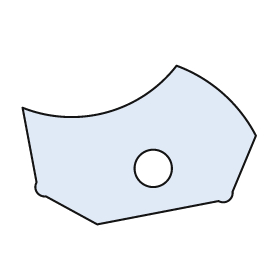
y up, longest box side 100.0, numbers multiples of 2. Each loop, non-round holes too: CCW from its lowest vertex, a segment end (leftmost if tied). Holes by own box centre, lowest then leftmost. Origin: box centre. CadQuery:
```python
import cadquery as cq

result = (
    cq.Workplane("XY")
    .moveTo(-18.0, -34.0)
    .lineTo(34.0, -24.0)
    .threePointArc((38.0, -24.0), (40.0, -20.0))
    .lineTo(50.0, 4.0)
    .threePointArc((36.0, 22.0), (16.0, 34.0))
    .threePointArc((-14.0, 14.0), (-50.0, 16.0))
    .lineTo(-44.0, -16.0)
    .threePointArc((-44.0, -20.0), (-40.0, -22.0))
    .close()
    .moveTo(6.0, -10.0)
    .circle(8.0)
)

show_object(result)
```